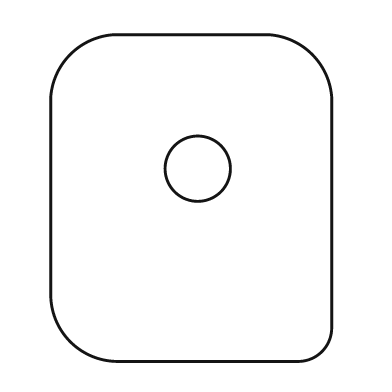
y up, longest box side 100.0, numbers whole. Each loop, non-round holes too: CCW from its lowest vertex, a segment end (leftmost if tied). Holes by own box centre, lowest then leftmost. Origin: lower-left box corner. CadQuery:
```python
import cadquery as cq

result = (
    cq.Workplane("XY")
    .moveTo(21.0, 0.0)
    .lineTo(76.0, 0.0)
    .threePointArc((83.0, 3.0), (86.0, 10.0))
    .lineTo(86.0, 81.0)
    .threePointArc((80.0, 94.0), (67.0, 100.0))
    .lineTo(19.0, 100.0)
    .threePointArc((6.0, 94.0), (0.0, 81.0))
    .lineTo(0.0, 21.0)
    .threePointArc((6.0, 6.0), (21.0, 0.0))
    .close()
    .moveTo(45.0, 59.0)
    .circle(10.0)
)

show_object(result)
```